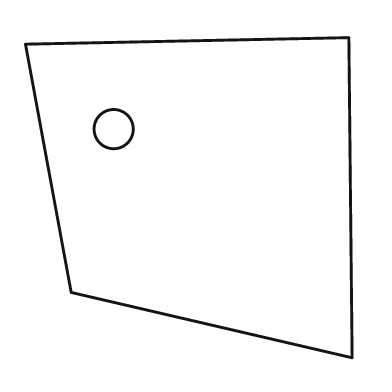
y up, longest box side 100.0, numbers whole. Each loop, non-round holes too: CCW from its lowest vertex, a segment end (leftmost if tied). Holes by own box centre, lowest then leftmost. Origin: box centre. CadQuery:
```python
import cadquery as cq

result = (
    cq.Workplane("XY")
    .moveTo(50.0, -49.0)
    .lineTo(49.0, 49.0)
    .lineTo(-50.0, 47.0)
    .lineTo(-36.0, -29.0)
    .close()
    .moveTo(-23.0, 21.0)
    .circle(6.0)
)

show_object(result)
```